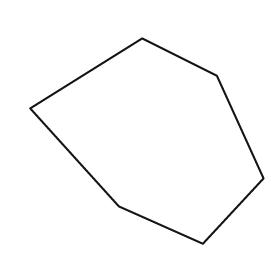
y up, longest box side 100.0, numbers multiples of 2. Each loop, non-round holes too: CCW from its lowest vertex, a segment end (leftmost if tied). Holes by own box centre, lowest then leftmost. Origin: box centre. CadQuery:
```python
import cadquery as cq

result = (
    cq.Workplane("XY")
    .moveTo(24.0, -44.0)
    .lineTo(50.0, -16.0)
    .lineTo(30.0, 28.0)
    .lineTo(-2.0, 44.0)
    .lineTo(-50.0, 14.0)
    .lineTo(-12.0, -28.0)
    .close()
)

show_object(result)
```